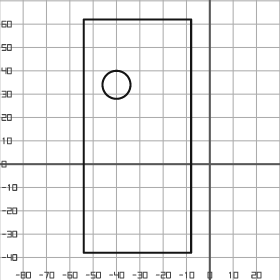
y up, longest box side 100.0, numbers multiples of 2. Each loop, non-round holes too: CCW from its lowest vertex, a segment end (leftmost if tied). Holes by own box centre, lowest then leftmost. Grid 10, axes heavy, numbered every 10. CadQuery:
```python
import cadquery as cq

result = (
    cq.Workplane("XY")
    .moveTo(-54.0, -38.0)
    .lineTo(-8.0, -38.0)
    .lineTo(-8.0, 62.0)
    .lineTo(-54.0, 62.0)
    .close()
    .moveTo(-40.0, 34.0)
    .circle(6.0)
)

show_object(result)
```